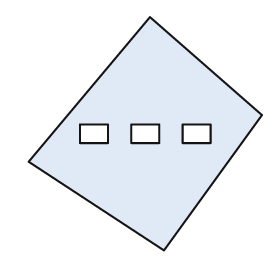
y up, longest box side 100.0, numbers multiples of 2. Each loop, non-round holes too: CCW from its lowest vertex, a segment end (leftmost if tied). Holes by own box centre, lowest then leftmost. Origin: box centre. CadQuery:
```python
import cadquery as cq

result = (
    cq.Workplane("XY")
    .moveTo(8.0, -50.0)
    .lineTo(50.0, 8.0)
    .lineTo(2.0, 50.0)
    .lineTo(-50.0, -12.0)
    .close()
    .moveTo(-28.0, -4.0)
    .lineTo(-16.0, -4.0)
    .lineTo(-16.0, 4.0)
    .lineTo(-28.0, 4.0)
    .close()
    .moveTo(-6.0, -4.0)
    .lineTo(6.0, -4.0)
    .lineTo(6.0, 4.0)
    .lineTo(-6.0, 4.0)
    .close()
    .moveTo(16.0, -4.0)
    .lineTo(28.0, -4.0)
    .lineTo(28.0, 4.0)
    .lineTo(16.0, 4.0)
    .close()
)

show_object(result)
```